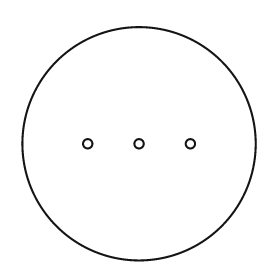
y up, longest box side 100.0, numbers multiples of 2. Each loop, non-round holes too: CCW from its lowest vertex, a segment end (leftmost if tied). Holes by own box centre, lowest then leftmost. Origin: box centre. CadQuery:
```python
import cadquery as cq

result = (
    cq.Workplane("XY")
    .moveTo(0.0, 0.0)
    .circle(50.0)
    .moveTo(-22.0, 0.0)
    .circle(2.0)
    .moveTo(0.0, 0.0)
    .circle(2.0)
    .moveTo(22.0, 0.0)
    .circle(2.0)
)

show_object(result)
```